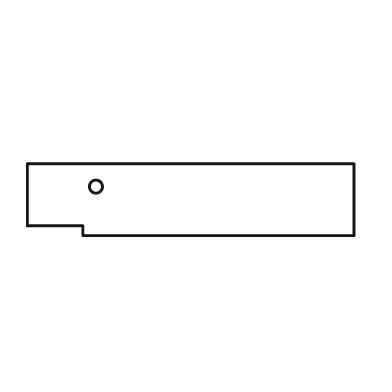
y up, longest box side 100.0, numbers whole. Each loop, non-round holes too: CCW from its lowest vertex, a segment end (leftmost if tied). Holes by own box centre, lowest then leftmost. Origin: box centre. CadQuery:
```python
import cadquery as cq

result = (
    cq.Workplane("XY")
    .moveTo(-33.0, -11.0)
    .lineTo(50.0, -11.0)
    .lineTo(50.0, 11.0)
    .lineTo(-50.0, 11.0)
    .lineTo(-50.0, -8.0)
    .lineTo(-33.0, -8.0)
    .close()
    .moveTo(-29.0, 4.0)
    .circle(2.0)
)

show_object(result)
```